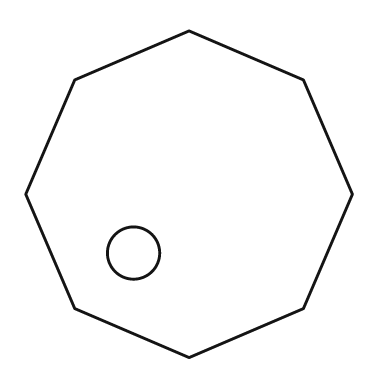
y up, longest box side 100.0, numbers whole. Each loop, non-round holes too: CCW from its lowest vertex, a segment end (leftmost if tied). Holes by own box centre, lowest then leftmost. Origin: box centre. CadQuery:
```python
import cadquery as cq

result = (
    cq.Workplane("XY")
    .moveTo(0.0, -50.0)
    .lineTo(35.0, -35.0)
    .lineTo(50.0, 0.0)
    .lineTo(35.0, 35.0)
    .lineTo(0.0, 50.0)
    .lineTo(-35.0, 35.0)
    .lineTo(-50.0, 0.0)
    .lineTo(-35.0, -35.0)
    .close()
    .moveTo(-17.0, -18.0)
    .circle(8.0)
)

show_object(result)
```